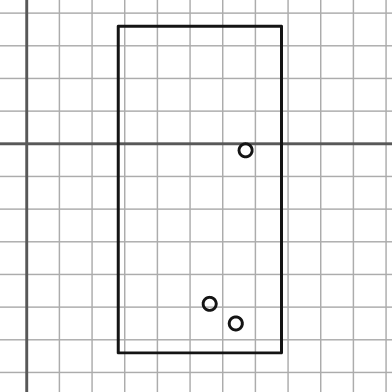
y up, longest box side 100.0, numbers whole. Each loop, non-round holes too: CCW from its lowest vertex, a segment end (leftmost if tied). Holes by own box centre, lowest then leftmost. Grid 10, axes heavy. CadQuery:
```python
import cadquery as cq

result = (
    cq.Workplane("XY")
    .moveTo(28.0, -64.0)
    .lineTo(78.0, -64.0)
    .lineTo(78.0, 36.0)
    .lineTo(28.0, 36.0)
    .close()
    .moveTo(64.0, -55.0)
    .circle(2.0)
    .moveTo(56.0, -49.0)
    .circle(2.0)
    .moveTo(67.0, -2.0)
    .circle(2.0)
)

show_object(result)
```